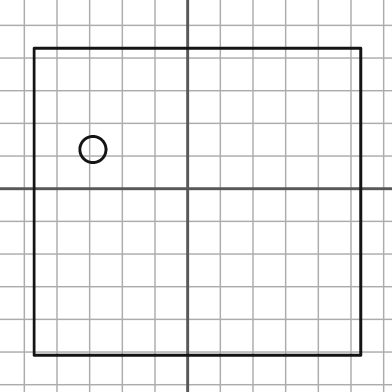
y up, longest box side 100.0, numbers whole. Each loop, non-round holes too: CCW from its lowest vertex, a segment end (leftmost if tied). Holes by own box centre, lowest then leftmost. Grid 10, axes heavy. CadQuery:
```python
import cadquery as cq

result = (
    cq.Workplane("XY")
    .moveTo(-47.0, -51.0)
    .lineTo(53.0, -51.0)
    .lineTo(53.0, 43.0)
    .lineTo(-47.0, 43.0)
    .close()
    .moveTo(-29.0, 12.0)
    .circle(4.0)
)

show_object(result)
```